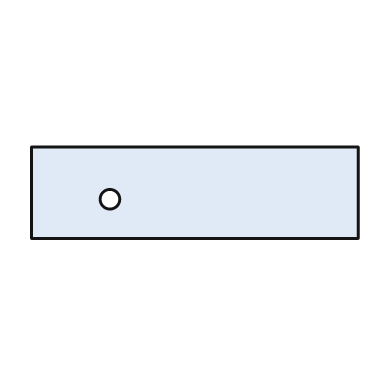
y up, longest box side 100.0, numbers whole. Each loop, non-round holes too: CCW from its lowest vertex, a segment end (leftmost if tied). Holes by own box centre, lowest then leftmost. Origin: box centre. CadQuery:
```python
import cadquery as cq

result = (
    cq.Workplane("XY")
    .moveTo(-50.0, -14.0)
    .lineTo(50.0, -14.0)
    .lineTo(50.0, 14.0)
    .lineTo(-50.0, 14.0)
    .close()
    .moveTo(-26.0, -2.0)
    .circle(3.0)
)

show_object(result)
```